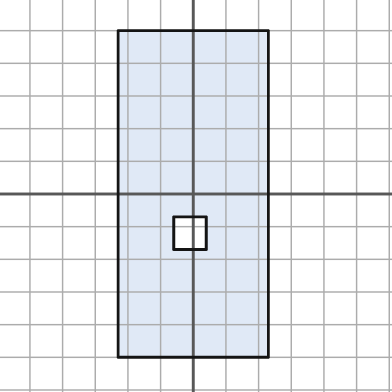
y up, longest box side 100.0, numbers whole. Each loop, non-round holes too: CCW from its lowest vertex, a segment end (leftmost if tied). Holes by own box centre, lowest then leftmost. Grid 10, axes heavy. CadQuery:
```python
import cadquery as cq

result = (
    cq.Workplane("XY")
    .moveTo(-23.0, -50.0)
    .lineTo(23.0, -50.0)
    .lineTo(23.0, 50.0)
    .lineTo(-23.0, 50.0)
    .close()
    .moveTo(-6.0, -17.0)
    .lineTo(4.0, -17.0)
    .lineTo(4.0, -7.0)
    .lineTo(-6.0, -7.0)
    .close()
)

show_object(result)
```